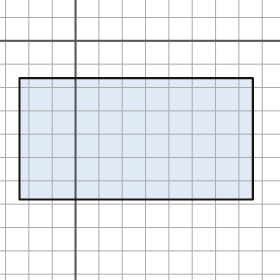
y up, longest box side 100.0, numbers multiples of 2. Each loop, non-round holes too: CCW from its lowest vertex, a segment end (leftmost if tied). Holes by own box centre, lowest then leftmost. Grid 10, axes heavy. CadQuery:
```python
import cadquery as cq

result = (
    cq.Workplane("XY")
    .moveTo(-24.0, -68.0)
    .lineTo(76.0, -68.0)
    .lineTo(76.0, -16.0)
    .lineTo(-24.0, -16.0)
    .close()
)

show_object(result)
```